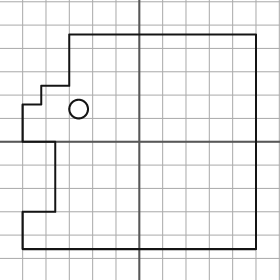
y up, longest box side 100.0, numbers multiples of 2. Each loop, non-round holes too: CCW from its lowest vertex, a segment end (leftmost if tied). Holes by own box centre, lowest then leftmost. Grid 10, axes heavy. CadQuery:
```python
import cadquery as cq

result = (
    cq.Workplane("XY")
    .moveTo(-50.0, -46.0)
    .lineTo(50.0, -46.0)
    .lineTo(50.0, 46.0)
    .lineTo(-30.0, 46.0)
    .lineTo(-30.0, 24.0)
    .lineTo(-42.0, 24.0)
    .lineTo(-42.0, 16.0)
    .lineTo(-50.0, 16.0)
    .lineTo(-50.0, 0.0)
    .lineTo(-36.0, 0.0)
    .lineTo(-36.0, -30.0)
    .lineTo(-50.0, -30.0)
    .close()
    .moveTo(-26.0, 14.0)
    .circle(4.0)
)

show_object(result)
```